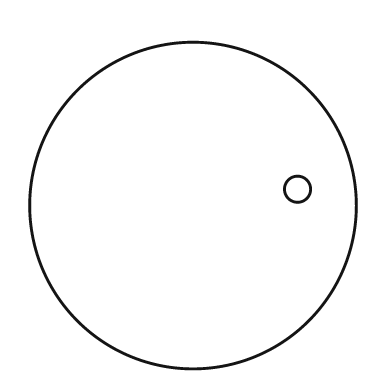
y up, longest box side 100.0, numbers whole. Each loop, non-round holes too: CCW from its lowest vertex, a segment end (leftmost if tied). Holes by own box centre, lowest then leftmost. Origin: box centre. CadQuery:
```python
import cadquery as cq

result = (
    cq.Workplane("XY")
    .moveTo(0.0, 0.0)
    .circle(50.0)
    .moveTo(32.0, 5.0)
    .circle(4.0)
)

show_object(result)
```